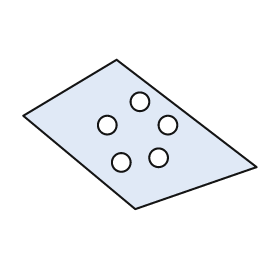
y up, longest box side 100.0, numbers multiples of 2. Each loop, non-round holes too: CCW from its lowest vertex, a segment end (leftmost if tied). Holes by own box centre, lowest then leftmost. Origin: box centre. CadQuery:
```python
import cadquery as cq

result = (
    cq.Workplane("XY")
    .moveTo(-2.0, -32.0)
    .lineTo(50.0, -14.0)
    .lineTo(-10.0, 32.0)
    .lineTo(-50.0, 8.0)
    .close()
    .moveTo(-8.0, -12.0)
    .circle(4.0)
    .moveTo(8.0, -10.0)
    .circle(4.0)
    .moveTo(-14.0, 4.0)
    .circle(4.0)
    .moveTo(12.0, 4.0)
    .circle(4.0)
    .moveTo(0.0, 14.0)
    .circle(4.0)
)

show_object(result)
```